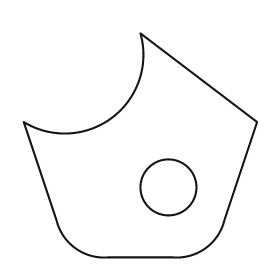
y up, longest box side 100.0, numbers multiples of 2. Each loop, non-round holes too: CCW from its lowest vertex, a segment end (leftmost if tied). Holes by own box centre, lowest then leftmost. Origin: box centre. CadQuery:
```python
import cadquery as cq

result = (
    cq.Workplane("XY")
    .moveTo(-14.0, -48.0)
    .lineTo(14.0, -48.0)
    .threePointArc((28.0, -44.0), (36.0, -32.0))
    .lineTo(50.0, 10.0)
    .lineTo(0.0, 48.0)
    .threePointArc((-12.0, 12.0), (-50.0, 10.0))
    .lineTo(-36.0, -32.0)
    .threePointArc((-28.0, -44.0), (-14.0, -48.0))
    .close()
    .moveTo(12.0, -18.0)
    .circle(12.0)
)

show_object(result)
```